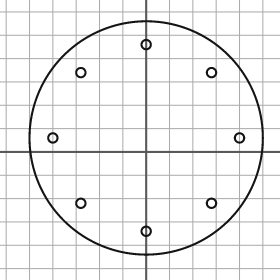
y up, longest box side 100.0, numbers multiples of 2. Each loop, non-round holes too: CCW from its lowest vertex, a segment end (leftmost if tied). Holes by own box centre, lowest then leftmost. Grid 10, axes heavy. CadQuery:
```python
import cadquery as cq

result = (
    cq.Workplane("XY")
    .moveTo(0.0, 6.0)
    .circle(50.0)
    .moveTo(0.0, -34.0)
    .circle(2.0)
    .moveTo(-28.0, -22.0)
    .circle(2.0)
    .moveTo(28.0, -22.0)
    .circle(2.0)
    .moveTo(-40.0, 6.0)
    .circle(2.0)
    .moveTo(40.0, 6.0)
    .circle(2.0)
    .moveTo(-28.0, 34.0)
    .circle(2.0)
    .moveTo(28.0, 34.0)
    .circle(2.0)
    .moveTo(0.0, 46.0)
    .circle(2.0)
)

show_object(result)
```